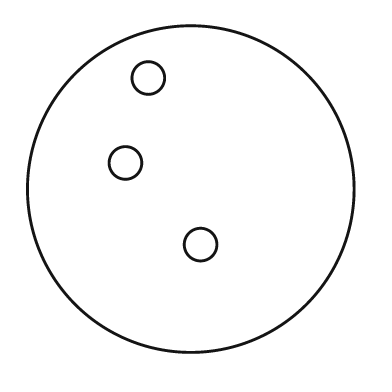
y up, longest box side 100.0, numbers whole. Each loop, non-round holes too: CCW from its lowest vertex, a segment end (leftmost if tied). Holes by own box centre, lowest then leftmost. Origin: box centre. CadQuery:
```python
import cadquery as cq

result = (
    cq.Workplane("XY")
    .moveTo(0.0, 0.0)
    .circle(50.0)
    .moveTo(3.0, -17.0)
    .circle(5.0)
    .moveTo(-20.0, 8.0)
    .circle(5.0)
    .moveTo(-13.0, 34.0)
    .circle(5.0)
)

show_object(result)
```